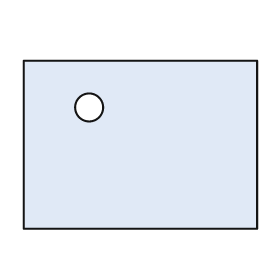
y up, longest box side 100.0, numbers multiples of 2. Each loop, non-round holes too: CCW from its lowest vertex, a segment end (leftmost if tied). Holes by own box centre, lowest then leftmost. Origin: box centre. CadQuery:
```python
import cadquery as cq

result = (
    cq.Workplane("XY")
    .moveTo(-50.0, -36.0)
    .lineTo(50.0, -36.0)
    .lineTo(50.0, 36.0)
    .lineTo(-50.0, 36.0)
    .close()
    .moveTo(-22.0, 16.0)
    .circle(6.0)
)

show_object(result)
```